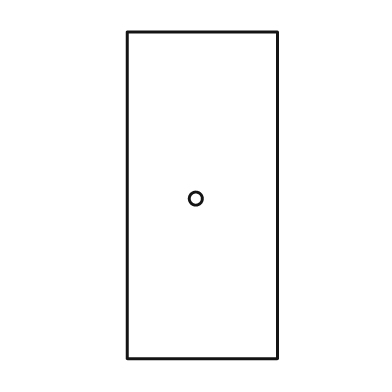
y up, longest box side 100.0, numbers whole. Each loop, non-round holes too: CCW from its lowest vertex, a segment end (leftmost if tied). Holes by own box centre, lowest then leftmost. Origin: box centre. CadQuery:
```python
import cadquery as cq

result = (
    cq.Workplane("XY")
    .moveTo(-23.0, -50.0)
    .lineTo(23.0, -50.0)
    .lineTo(23.0, 50.0)
    .lineTo(-23.0, 50.0)
    .close()
    .moveTo(-2.0, -1.0)
    .circle(2.0)
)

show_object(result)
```